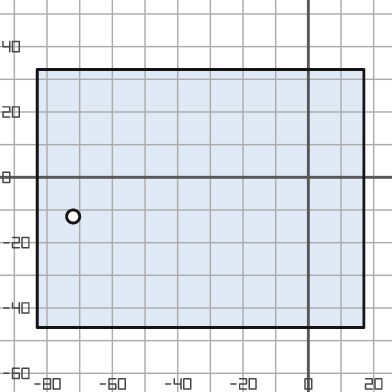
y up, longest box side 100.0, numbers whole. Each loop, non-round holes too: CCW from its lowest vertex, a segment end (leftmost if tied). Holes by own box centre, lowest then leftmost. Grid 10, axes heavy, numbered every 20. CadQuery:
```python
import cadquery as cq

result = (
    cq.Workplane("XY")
    .moveTo(-83.0, -46.0)
    .lineTo(17.0, -46.0)
    .lineTo(17.0, 33.0)
    .lineTo(-83.0, 33.0)
    .close()
    .moveTo(-72.0, -12.0)
    .circle(2.0)
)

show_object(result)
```